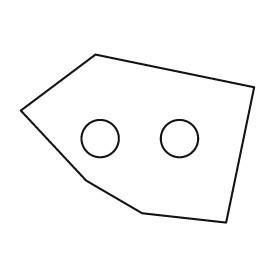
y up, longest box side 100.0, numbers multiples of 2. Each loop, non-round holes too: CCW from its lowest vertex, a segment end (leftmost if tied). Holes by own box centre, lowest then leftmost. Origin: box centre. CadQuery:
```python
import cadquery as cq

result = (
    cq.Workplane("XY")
    .moveTo(38.0, -36.0)
    .lineTo(50.0, 22.0)
    .lineTo(-18.0, 36.0)
    .lineTo(-50.0, 12.0)
    .lineTo(-22.0, -18.0)
    .lineTo(2.0, -32.0)
    .close()
    .moveTo(-16.0, 0.0)
    .circle(8.0)
    .moveTo(18.0, 0.0)
    .circle(8.0)
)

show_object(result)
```